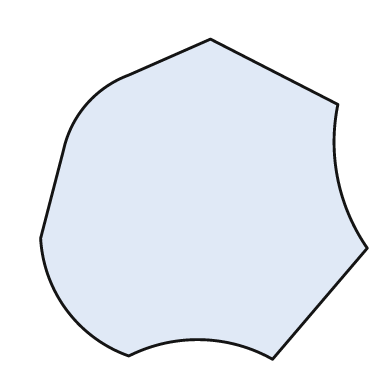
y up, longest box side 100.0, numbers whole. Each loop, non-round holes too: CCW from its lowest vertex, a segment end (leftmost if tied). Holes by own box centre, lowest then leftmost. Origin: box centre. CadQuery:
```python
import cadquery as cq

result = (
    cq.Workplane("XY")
    .moveTo(21.0, -49.0)
    .lineTo(50.0, -15.0)
    .threePointArc((41.0, 6.0), (41.0, 29.0))
    .lineTo(2.0, 49.0)
    .lineTo(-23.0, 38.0)
    .threePointArc((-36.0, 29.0), (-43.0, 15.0))
    .lineTo(-50.0, -12.0)
    .threePointArc((-42.0, -34.0), (-23.0, -48.0))
    .threePointArc((-1.0, -43.0), (21.0, -49.0))
    .close()
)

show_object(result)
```